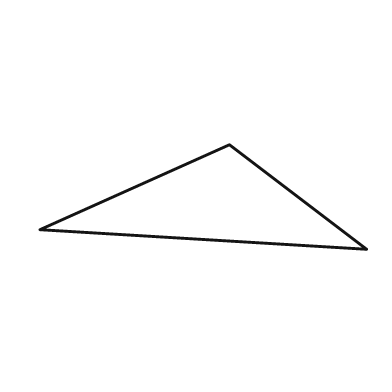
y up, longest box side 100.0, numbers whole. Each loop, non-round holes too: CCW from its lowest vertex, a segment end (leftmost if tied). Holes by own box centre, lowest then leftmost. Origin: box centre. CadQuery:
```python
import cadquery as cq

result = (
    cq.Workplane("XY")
    .moveTo(50.0, -16.0)
    .lineTo(8.0, 16.0)
    .lineTo(-50.0, -10.0)
    .close()
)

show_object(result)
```